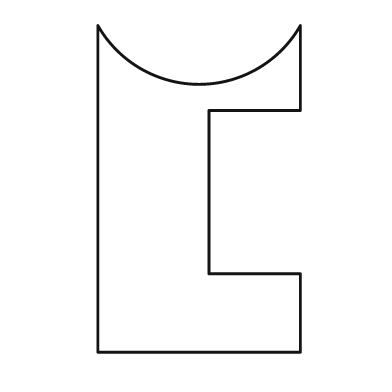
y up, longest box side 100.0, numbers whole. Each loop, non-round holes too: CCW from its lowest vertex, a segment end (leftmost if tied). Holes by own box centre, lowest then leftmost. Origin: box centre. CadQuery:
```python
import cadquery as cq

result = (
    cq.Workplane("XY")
    .moveTo(-31.0, -50.0)
    .lineTo(31.0, -50.0)
    .lineTo(31.0, -26.0)
    .lineTo(3.0, -26.0)
    .lineTo(3.0, 24.0)
    .lineTo(31.0, 24.0)
    .lineTo(31.0, 50.0)
    .threePointArc((0.0, 32.0), (-31.0, 50.0))
    .close()
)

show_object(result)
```